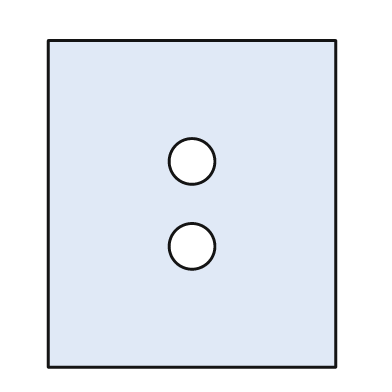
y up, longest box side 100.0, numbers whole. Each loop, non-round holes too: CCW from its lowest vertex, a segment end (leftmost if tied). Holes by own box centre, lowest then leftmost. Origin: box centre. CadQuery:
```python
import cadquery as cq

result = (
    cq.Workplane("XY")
    .moveTo(-44.0, -50.0)
    .lineTo(44.0, -50.0)
    .lineTo(44.0, 50.0)
    .lineTo(-44.0, 50.0)
    .close()
    .moveTo(0.0, -13.0)
    .circle(7.0)
    .moveTo(0.0, 13.0)
    .circle(7.0)
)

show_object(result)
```